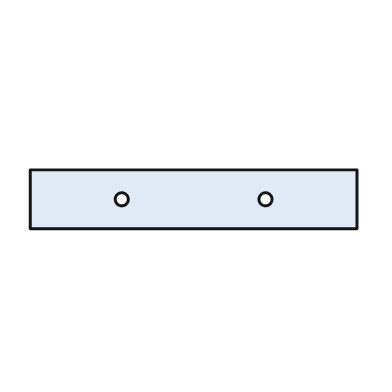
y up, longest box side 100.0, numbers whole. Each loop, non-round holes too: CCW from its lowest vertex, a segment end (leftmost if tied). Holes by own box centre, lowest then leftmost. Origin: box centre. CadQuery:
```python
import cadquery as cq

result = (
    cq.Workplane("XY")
    .moveTo(-50.0, -9.0)
    .lineTo(50.0, -9.0)
    .lineTo(50.0, 9.0)
    .lineTo(-50.0, 9.0)
    .close()
    .moveTo(-22.0, 0.0)
    .circle(2.0)
    .moveTo(22.0, 0.0)
    .circle(2.0)
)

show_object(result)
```